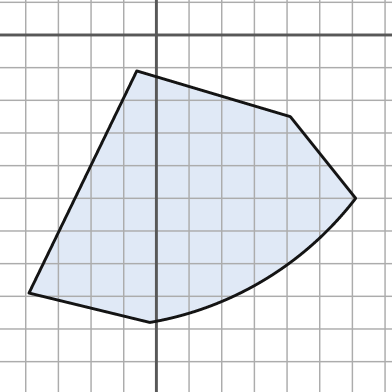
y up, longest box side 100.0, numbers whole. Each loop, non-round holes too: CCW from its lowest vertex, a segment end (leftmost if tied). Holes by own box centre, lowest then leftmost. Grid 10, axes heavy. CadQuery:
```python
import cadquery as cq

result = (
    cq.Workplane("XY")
    .moveTo(-2.0, -88.0)
    .threePointArc((33.0, -75.0), (61.0, -50.0))
    .lineTo(41.0, -25.0)
    .lineTo(-6.0, -11.0)
    .lineTo(-39.0, -79.0)
    .close()
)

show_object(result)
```